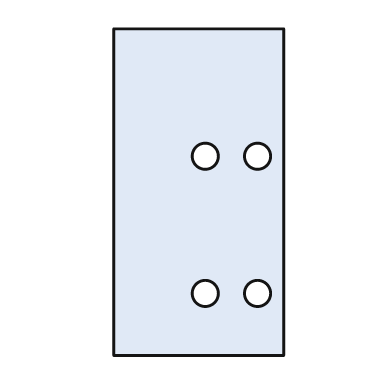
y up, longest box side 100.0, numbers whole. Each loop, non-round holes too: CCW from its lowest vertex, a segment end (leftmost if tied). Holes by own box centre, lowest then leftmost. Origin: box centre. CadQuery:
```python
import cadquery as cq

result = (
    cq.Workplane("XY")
    .moveTo(-26.0, -50.0)
    .lineTo(26.0, -50.0)
    .lineTo(26.0, 50.0)
    .lineTo(-26.0, 50.0)
    .close()
    .moveTo(2.0, -31.0)
    .circle(4.0)
    .moveTo(18.0, -31.0)
    .circle(4.0)
    .moveTo(2.0, 11.0)
    .circle(4.0)
    .moveTo(18.0, 11.0)
    .circle(4.0)
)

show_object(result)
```